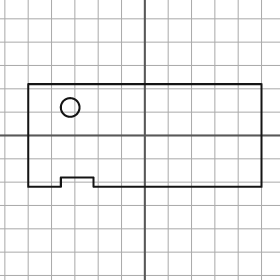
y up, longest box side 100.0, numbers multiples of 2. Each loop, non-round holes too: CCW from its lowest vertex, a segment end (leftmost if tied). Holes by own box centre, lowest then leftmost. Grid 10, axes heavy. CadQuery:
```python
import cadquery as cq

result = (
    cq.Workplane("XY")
    .moveTo(-50.0, -22.0)
    .lineTo(-36.0, -22.0)
    .lineTo(-36.0, -18.0)
    .lineTo(-22.0, -18.0)
    .lineTo(-22.0, -22.0)
    .lineTo(50.0, -22.0)
    .lineTo(50.0, 22.0)
    .lineTo(-50.0, 22.0)
    .close()
    .moveTo(-32.0, 12.0)
    .circle(4.0)
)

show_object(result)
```